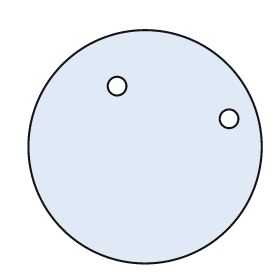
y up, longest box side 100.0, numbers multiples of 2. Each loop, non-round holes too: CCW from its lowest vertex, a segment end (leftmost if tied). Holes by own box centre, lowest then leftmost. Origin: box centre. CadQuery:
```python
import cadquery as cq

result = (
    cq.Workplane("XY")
    .moveTo(0.0, 0.0)
    .circle(50.0)
    .moveTo(36.0, 12.0)
    .circle(4.0)
    .moveTo(-12.0, 26.0)
    .circle(4.0)
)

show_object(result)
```